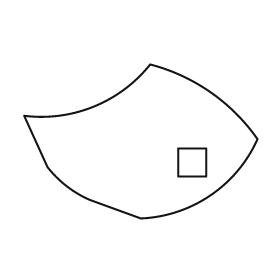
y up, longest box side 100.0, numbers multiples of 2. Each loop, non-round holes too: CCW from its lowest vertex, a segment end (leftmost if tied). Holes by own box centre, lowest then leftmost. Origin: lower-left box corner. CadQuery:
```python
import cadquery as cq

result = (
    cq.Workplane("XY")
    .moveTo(50.0, 0.0)
    .threePointArc((80.0, 10.0), (100.0, 34.0))
    .threePointArc((80.0, 54.0), (54.0, 66.0))
    .threePointArc((30.0, 48.0), (0.0, 44.0))
    .lineTo(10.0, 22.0)
    .threePointArc((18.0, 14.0), (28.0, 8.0))
    .close()
    .moveTo(66.0, 18.0)
    .lineTo(78.0, 18.0)
    .lineTo(78.0, 30.0)
    .lineTo(66.0, 30.0)
    .close()
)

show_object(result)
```